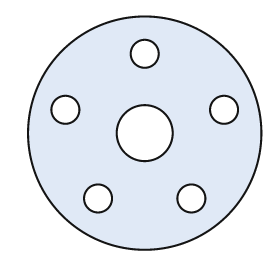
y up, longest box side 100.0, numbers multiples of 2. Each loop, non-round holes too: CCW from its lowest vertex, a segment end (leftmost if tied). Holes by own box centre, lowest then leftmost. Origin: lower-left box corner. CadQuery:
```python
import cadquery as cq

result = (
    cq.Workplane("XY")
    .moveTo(50.0, 50.0)
    .circle(50.0)
    .moveTo(30.0, 22.0)
    .circle(6.0)
    .moveTo(70.0, 22.0)
    .circle(6.0)
    .moveTo(50.0, 50.0)
    .circle(12.0)
    .moveTo(16.0, 60.0)
    .circle(6.0)
    .moveTo(84.0, 60.0)
    .circle(6.0)
    .moveTo(50.0, 84.0)
    .circle(6.0)
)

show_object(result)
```